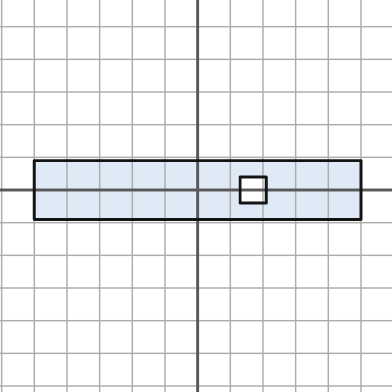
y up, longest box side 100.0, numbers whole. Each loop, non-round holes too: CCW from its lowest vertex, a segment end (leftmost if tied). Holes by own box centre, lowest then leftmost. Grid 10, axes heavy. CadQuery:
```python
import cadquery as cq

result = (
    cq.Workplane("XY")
    .moveTo(-50.0, -9.0)
    .lineTo(50.0, -9.0)
    .lineTo(50.0, 9.0)
    .lineTo(-50.0, 9.0)
    .close()
    .moveTo(13.0, -4.0)
    .lineTo(21.0, -4.0)
    .lineTo(21.0, 4.0)
    .lineTo(13.0, 4.0)
    .close()
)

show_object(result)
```